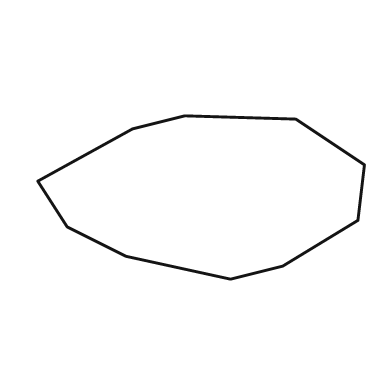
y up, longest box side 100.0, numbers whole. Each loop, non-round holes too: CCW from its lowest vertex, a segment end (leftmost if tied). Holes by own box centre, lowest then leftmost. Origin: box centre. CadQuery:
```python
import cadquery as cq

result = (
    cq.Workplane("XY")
    .moveTo(9.0, -25.0)
    .lineTo(25.0, -21.0)
    .lineTo(48.0, -7.0)
    .lineTo(50.0, 10.0)
    .lineTo(29.0, 24.0)
    .lineTo(-5.0, 25.0)
    .lineTo(-21.0, 21.0)
    .lineTo(-50.0, 5.0)
    .lineTo(-41.0, -9.0)
    .lineTo(-23.0, -18.0)
    .close()
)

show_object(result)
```